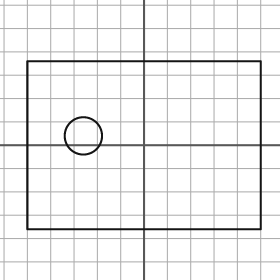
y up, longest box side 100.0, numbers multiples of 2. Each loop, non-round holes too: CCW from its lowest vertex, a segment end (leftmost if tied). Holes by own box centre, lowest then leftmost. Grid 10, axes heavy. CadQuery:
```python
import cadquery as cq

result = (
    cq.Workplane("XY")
    .moveTo(-50.0, -36.0)
    .lineTo(50.0, -36.0)
    .lineTo(50.0, 36.0)
    .lineTo(-50.0, 36.0)
    .close()
    .moveTo(-26.0, 4.0)
    .circle(8.0)
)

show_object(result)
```